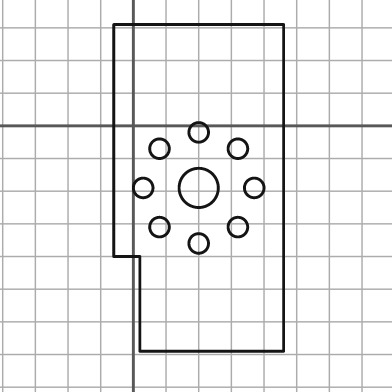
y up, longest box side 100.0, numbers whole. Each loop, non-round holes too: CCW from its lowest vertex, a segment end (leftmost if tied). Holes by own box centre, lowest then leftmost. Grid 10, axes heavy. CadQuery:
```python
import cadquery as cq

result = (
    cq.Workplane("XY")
    .moveTo(2.0, -69.0)
    .lineTo(46.0, -69.0)
    .lineTo(46.0, 31.0)
    .lineTo(-6.0, 31.0)
    .lineTo(-6.0, -40.0)
    .lineTo(2.0, -40.0)
    .close()
    .moveTo(20.0, -36.0)
    .circle(3.0)
    .moveTo(8.0, -31.0)
    .circle(3.0)
    .moveTo(32.0, -31.0)
    .circle(3.0)
    .moveTo(3.0, -19.0)
    .circle(3.0)
    .moveTo(20.0, -19.0)
    .circle(6.0)
    .moveTo(37.0, -19.0)
    .circle(3.0)
    .moveTo(8.0, -7.0)
    .circle(3.0)
    .moveTo(32.0, -7.0)
    .circle(3.0)
    .moveTo(20.0, -2.0)
    .circle(3.0)
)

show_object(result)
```